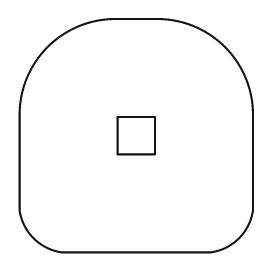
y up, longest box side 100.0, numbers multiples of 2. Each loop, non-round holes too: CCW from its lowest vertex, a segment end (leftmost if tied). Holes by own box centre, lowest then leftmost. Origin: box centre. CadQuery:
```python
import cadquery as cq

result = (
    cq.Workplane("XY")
    .moveTo(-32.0, -50.0)
    .lineTo(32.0, -50.0)
    .threePointArc((44.0, -44.0), (50.0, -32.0))
    .lineTo(50.0, 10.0)
    .threePointArc((38.0, 38.0), (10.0, 50.0))
    .lineTo(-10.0, 50.0)
    .threePointArc((-38.0, 38.0), (-50.0, 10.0))
    .lineTo(-50.0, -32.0)
    .threePointArc((-44.0, -44.0), (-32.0, -50.0))
    .close()
    .moveTo(-8.0, -8.0)
    .lineTo(8.0, -8.0)
    .lineTo(8.0, 8.0)
    .lineTo(-8.0, 8.0)
    .close()
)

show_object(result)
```